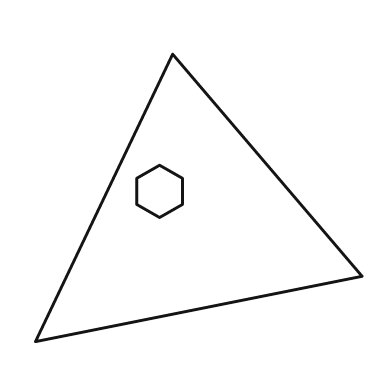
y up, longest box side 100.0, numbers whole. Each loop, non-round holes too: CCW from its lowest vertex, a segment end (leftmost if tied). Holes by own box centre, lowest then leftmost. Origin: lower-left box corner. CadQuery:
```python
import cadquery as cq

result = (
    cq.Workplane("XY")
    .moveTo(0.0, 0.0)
    .lineTo(100.0, 20.0)
    .lineTo(42.0, 88.0)
    .close()
    .moveTo(38.0, 38.0)
    .lineTo(45.0, 42.0)
    .lineTo(45.0, 50.0)
    .lineTo(38.0, 54.0)
    .lineTo(31.0, 50.0)
    .lineTo(31.0, 42.0)
    .close()
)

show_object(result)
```